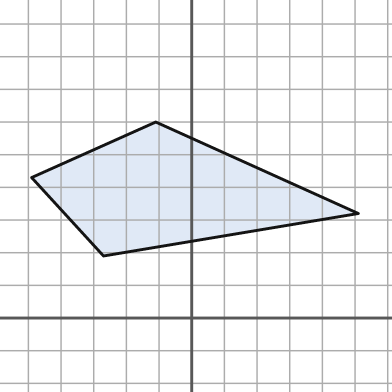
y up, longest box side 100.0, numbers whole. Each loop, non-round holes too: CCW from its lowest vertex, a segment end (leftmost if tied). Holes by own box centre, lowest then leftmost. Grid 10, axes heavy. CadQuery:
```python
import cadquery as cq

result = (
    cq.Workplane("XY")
    .moveTo(-27.0, 19.0)
    .lineTo(51.0, 32.0)
    .lineTo(-11.0, 60.0)
    .lineTo(-49.0, 43.0)
    .close()
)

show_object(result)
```